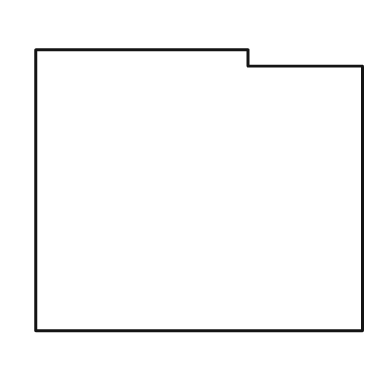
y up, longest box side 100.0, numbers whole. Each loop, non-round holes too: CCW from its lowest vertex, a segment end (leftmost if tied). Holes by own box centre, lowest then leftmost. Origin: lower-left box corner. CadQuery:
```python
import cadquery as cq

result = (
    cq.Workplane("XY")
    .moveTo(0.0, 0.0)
    .lineTo(100.0, 0.0)
    .lineTo(100.0, 81.0)
    .lineTo(65.0, 81.0)
    .lineTo(65.0, 86.0)
    .lineTo(0.0, 86.0)
    .close()
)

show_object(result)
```